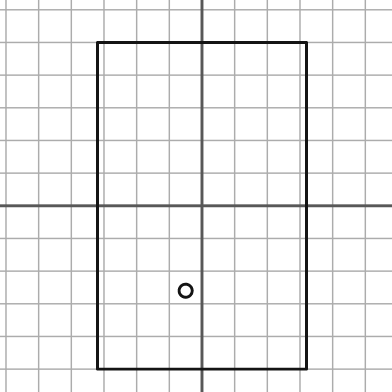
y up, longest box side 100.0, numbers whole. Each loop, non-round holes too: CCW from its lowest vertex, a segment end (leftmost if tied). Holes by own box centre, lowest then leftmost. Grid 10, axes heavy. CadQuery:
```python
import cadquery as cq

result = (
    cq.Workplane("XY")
    .moveTo(-32.0, -50.0)
    .lineTo(32.0, -50.0)
    .lineTo(32.0, 50.0)
    .lineTo(-32.0, 50.0)
    .close()
    .moveTo(-5.0, -26.0)
    .circle(2.0)
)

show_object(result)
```